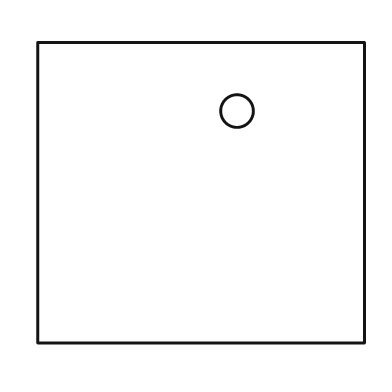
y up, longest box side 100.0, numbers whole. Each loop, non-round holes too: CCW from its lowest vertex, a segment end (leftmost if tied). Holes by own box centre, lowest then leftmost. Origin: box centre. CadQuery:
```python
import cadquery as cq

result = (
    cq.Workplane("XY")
    .moveTo(-50.0, -46.0)
    .lineTo(50.0, -46.0)
    .lineTo(50.0, 46.0)
    .lineTo(-50.0, 46.0)
    .close()
    .moveTo(11.0, 25.0)
    .circle(5.0)
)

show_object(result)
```